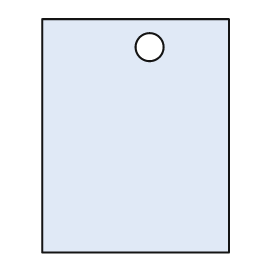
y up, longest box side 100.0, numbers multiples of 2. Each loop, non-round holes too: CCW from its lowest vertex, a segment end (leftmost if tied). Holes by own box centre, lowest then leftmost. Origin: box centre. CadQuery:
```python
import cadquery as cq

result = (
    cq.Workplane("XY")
    .moveTo(-40.0, -50.0)
    .lineTo(40.0, -50.0)
    .lineTo(40.0, 50.0)
    .lineTo(-40.0, 50.0)
    .close()
    .moveTo(6.0, 38.0)
    .circle(6.0)
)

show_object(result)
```